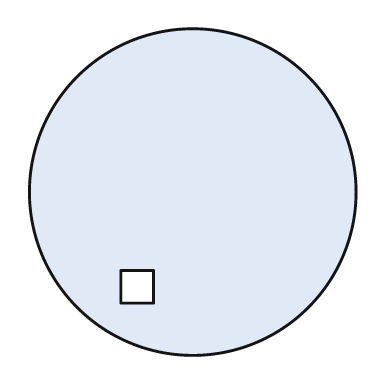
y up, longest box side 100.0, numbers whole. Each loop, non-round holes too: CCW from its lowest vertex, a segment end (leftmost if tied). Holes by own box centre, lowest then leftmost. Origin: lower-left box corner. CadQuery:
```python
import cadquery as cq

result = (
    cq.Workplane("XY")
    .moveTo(50.0, 50.0)
    .circle(50.0)
    .moveTo(28.0, 16.0)
    .lineTo(38.0, 16.0)
    .lineTo(38.0, 26.0)
    .lineTo(28.0, 26.0)
    .close()
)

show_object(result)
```